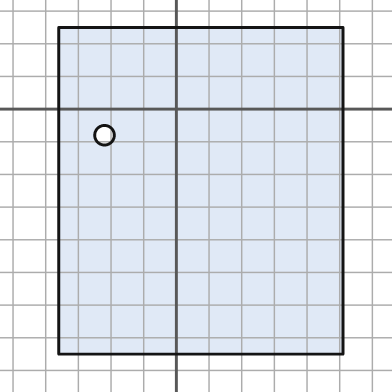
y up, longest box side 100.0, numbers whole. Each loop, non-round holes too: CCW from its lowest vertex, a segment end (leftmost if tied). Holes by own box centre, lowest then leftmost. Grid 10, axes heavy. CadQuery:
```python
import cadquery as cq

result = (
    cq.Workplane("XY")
    .moveTo(-36.0, -75.0)
    .lineTo(51.0, -75.0)
    .lineTo(51.0, 25.0)
    .lineTo(-36.0, 25.0)
    .close()
    .moveTo(-22.0, -8.0)
    .circle(3.0)
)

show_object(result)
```